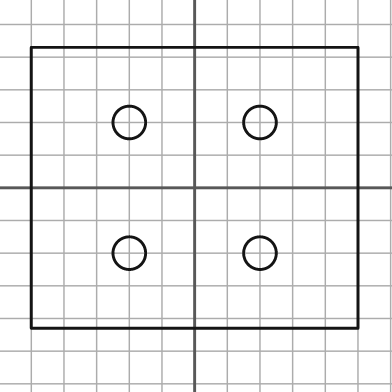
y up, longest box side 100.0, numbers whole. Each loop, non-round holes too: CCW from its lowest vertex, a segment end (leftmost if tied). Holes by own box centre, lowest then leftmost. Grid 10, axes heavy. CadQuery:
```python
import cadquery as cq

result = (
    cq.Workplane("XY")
    .moveTo(-50.0, -43.0)
    .lineTo(50.0, -43.0)
    .lineTo(50.0, 43.0)
    .lineTo(-50.0, 43.0)
    .close()
    .moveTo(-20.0, -20.0)
    .circle(5.0)
    .moveTo(20.0, -20.0)
    .circle(5.0)
    .moveTo(-20.0, 20.0)
    .circle(5.0)
    .moveTo(20.0, 20.0)
    .circle(5.0)
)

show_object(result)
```